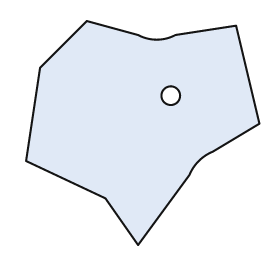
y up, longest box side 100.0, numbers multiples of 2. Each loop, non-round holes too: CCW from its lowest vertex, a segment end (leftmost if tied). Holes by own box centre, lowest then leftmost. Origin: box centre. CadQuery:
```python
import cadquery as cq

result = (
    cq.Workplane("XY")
    .moveTo(-2.0, -48.0)
    .lineTo(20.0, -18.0)
    .threePointArc((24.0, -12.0), (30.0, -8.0))
    .lineTo(50.0, 4.0)
    .lineTo(40.0, 46.0)
    .lineTo(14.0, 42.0)
    .threePointArc((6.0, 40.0), (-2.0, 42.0))
    .lineTo(-24.0, 48.0)
    .lineTo(-44.0, 28.0)
    .lineTo(-50.0, -12.0)
    .lineTo(-16.0, -28.0)
    .close()
    .moveTo(12.0, 16.0)
    .circle(4.0)
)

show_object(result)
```